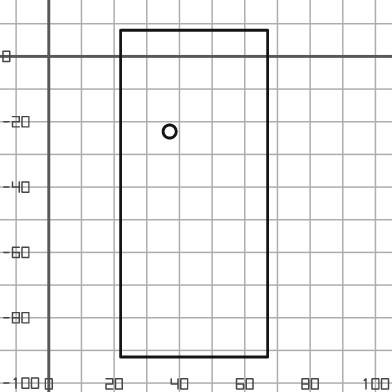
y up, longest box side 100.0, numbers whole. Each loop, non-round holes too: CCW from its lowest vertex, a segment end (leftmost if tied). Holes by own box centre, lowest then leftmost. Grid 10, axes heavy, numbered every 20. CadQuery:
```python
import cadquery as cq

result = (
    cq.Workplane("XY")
    .moveTo(22.0, -92.0)
    .lineTo(67.0, -92.0)
    .lineTo(67.0, 8.0)
    .lineTo(22.0, 8.0)
    .close()
    .moveTo(37.0, -23.0)
    .circle(2.0)
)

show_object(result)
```